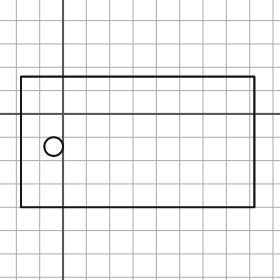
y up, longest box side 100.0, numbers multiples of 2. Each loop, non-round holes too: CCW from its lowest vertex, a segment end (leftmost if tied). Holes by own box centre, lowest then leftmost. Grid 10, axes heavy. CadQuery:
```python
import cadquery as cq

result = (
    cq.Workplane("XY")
    .moveTo(-18.0, -40.0)
    .lineTo(82.0, -40.0)
    .lineTo(82.0, 16.0)
    .lineTo(-18.0, 16.0)
    .close()
    .moveTo(-4.0, -14.0)
    .circle(4.0)
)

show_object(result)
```